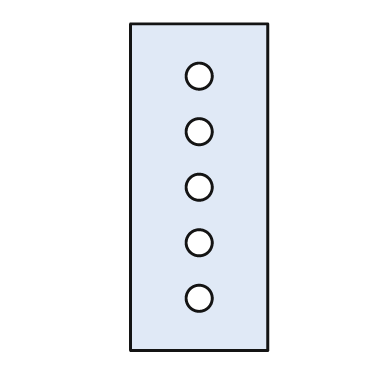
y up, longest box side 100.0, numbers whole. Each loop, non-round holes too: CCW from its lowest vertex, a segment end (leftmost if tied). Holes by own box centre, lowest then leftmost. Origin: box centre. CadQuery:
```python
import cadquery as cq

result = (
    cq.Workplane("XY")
    .moveTo(-21.0, -50.0)
    .lineTo(21.0, -50.0)
    .lineTo(21.0, 50.0)
    .lineTo(-21.0, 50.0)
    .close()
    .moveTo(0.0, -34.0)
    .circle(4.0)
    .moveTo(0.0, -17.0)
    .circle(4.0)
    .moveTo(0.0, 0.0)
    .circle(4.0)
    .moveTo(0.0, 17.0)
    .circle(4.0)
    .moveTo(0.0, 34.0)
    .circle(4.0)
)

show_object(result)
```